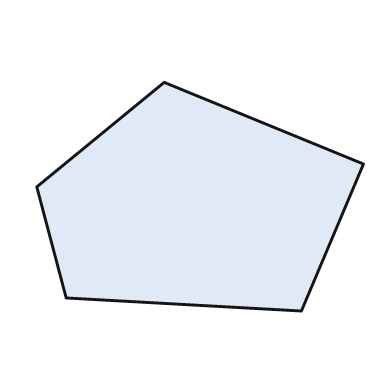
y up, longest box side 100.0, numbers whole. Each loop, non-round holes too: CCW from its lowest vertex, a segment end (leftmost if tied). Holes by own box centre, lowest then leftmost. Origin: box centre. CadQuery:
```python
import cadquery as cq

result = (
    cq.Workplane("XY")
    .moveTo(31.0, -35.0)
    .lineTo(50.0, 10.0)
    .lineTo(-11.0, 35.0)
    .lineTo(-50.0, 3.0)
    .lineTo(-41.0, -31.0)
    .close()
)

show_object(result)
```